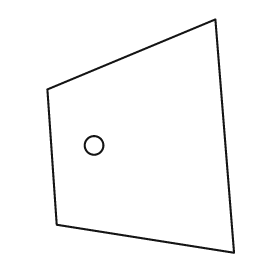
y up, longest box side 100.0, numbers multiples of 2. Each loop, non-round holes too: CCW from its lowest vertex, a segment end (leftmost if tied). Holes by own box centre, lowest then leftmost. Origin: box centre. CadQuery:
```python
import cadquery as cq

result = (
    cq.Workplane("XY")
    .moveTo(40.0, -50.0)
    .lineTo(32.0, 50.0)
    .lineTo(-40.0, 20.0)
    .lineTo(-36.0, -38.0)
    .close()
    .moveTo(-20.0, -4.0)
    .circle(4.0)
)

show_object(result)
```